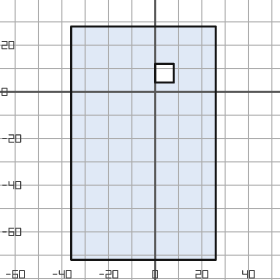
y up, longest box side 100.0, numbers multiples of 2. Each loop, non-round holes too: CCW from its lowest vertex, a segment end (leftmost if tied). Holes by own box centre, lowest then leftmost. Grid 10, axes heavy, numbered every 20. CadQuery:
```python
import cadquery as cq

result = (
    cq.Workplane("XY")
    .moveTo(-36.0, -72.0)
    .lineTo(26.0, -72.0)
    .lineTo(26.0, 28.0)
    .lineTo(-36.0, 28.0)
    .close()
    .moveTo(0.0, 4.0)
    .lineTo(8.0, 4.0)
    .lineTo(8.0, 12.0)
    .lineTo(0.0, 12.0)
    .close()
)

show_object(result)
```